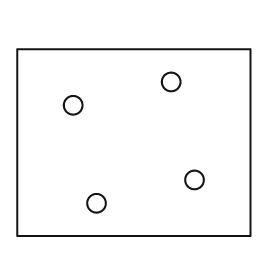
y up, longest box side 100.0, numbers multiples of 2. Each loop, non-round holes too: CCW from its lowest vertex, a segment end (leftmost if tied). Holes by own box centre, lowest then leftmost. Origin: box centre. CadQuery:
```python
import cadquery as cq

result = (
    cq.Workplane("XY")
    .moveTo(-50.0, -40.0)
    .lineTo(50.0, -40.0)
    .lineTo(50.0, 40.0)
    .lineTo(-50.0, 40.0)
    .close()
    .moveTo(-16.0, -26.0)
    .circle(4.0)
    .moveTo(26.0, -16.0)
    .circle(4.0)
    .moveTo(-26.0, 16.0)
    .circle(4.0)
    .moveTo(16.0, 26.0)
    .circle(4.0)
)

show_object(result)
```